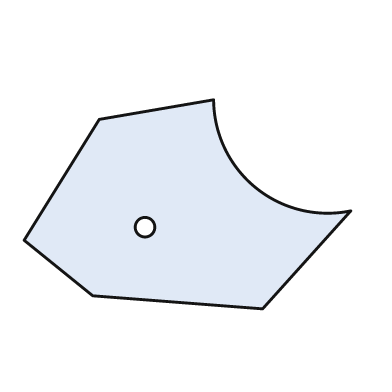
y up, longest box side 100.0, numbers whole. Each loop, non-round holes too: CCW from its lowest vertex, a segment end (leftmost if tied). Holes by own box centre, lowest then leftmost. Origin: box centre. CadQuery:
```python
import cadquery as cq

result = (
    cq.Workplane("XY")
    .moveTo(23.0, -32.0)
    .lineTo(50.0, -2.0)
    .threePointArc((21.0, 5.0), (8.0, 32.0))
    .lineTo(-27.0, 26.0)
    .lineTo(-50.0, -11.0)
    .lineTo(-29.0, -28.0)
    .close()
    .moveTo(-13.0, -7.0)
    .circle(3.0)
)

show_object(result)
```